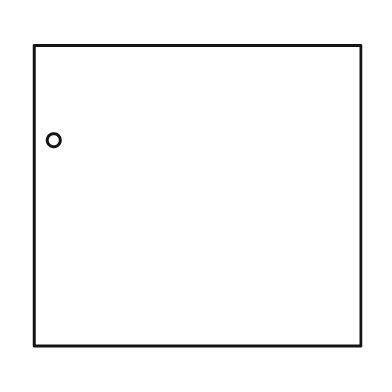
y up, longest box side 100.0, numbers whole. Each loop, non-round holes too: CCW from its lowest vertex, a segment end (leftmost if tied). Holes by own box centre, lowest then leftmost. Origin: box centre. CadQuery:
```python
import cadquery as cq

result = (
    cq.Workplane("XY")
    .moveTo(-50.0, -46.0)
    .lineTo(50.0, -46.0)
    .lineTo(50.0, 46.0)
    .lineTo(-50.0, 46.0)
    .close()
    .moveTo(-44.0, 17.0)
    .circle(2.0)
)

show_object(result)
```